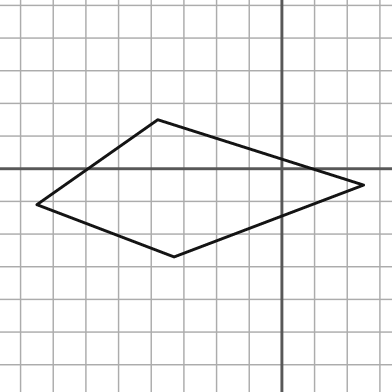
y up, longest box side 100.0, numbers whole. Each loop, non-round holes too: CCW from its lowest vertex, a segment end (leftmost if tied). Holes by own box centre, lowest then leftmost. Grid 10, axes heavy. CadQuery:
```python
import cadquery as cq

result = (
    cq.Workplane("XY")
    .moveTo(-33.0, -27.0)
    .lineTo(25.0, -5.0)
    .lineTo(-38.0, 15.0)
    .lineTo(-75.0, -11.0)
    .close()
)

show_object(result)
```